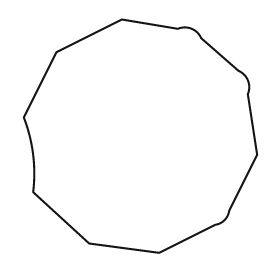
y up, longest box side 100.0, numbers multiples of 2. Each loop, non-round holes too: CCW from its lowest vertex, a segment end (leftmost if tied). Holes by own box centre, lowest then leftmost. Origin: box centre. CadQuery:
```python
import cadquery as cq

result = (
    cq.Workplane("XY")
    .moveTo(8.0, -50.0)
    .lineTo(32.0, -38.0)
    .threePointArc((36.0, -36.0), (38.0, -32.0))
    .lineTo(50.0, -8.0)
    .lineTo(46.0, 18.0)
    .threePointArc((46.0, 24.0), (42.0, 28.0))
    .lineTo(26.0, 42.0)
    .threePointArc((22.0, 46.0), (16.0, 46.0))
    .lineTo(-8.0, 50.0)
    .lineTo(-36.0, 36.0)
    .lineTo(-50.0, 8.0)
    .threePointArc((-46.0, -8.0), (-46.0, -24.0))
    .lineTo(-22.0, -46.0)
    .close()
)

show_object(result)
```